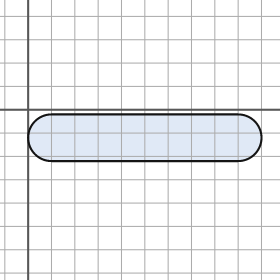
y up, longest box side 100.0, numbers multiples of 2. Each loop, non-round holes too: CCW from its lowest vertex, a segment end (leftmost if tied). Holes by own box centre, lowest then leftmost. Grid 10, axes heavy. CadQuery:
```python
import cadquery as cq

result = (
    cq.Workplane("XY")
    .moveTo(10.0, -22.0)
    .lineTo(90.0, -22.0)
    .threePointArc((100.0, -12.0), (90.0, -2.0))
    .lineTo(10.0, -2.0)
    .threePointArc((0.0, -12.0), (10.0, -22.0))
    .close()
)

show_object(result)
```